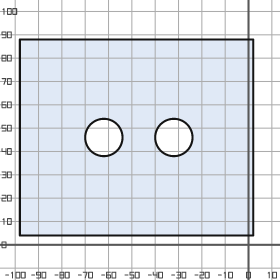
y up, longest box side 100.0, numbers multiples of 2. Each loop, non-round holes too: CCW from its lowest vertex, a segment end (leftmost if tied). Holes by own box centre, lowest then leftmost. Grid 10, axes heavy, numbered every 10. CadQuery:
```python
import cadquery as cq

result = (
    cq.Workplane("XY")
    .moveTo(-98.0, 4.0)
    .lineTo(2.0, 4.0)
    .lineTo(2.0, 88.0)
    .lineTo(-98.0, 88.0)
    .close()
    .moveTo(-62.0, 46.0)
    .circle(8.0)
    .moveTo(-32.0, 46.0)
    .circle(8.0)
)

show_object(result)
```